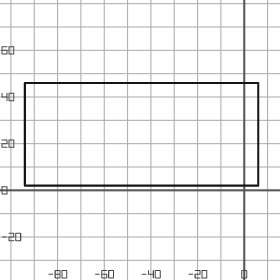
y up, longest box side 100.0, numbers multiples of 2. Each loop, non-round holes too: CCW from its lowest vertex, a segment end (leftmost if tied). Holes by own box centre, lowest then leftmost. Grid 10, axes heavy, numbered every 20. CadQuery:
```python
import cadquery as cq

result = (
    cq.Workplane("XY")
    .moveTo(-94.0, 2.0)
    .lineTo(6.0, 2.0)
    .lineTo(6.0, 46.0)
    .lineTo(-94.0, 46.0)
    .close()
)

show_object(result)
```